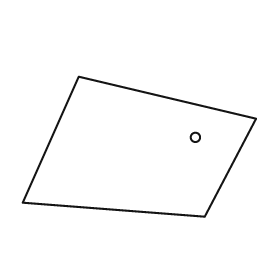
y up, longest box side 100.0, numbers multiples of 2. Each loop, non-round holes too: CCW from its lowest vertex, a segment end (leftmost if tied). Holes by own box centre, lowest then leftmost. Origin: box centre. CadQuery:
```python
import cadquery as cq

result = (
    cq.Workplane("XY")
    .moveTo(28.0, -30.0)
    .lineTo(50.0, 12.0)
    .lineTo(-26.0, 30.0)
    .lineTo(-50.0, -24.0)
    .close()
    .moveTo(24.0, 4.0)
    .circle(2.0)
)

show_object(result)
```